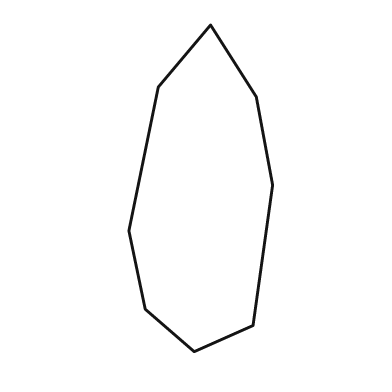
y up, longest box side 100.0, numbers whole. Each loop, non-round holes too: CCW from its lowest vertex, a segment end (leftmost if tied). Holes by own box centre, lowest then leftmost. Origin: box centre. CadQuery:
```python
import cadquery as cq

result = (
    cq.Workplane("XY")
    .moveTo(-2.0, -50.0)
    .lineTo(16.0, -42.0)
    .lineTo(22.0, 1.0)
    .lineTo(17.0, 28.0)
    .lineTo(3.0, 50.0)
    .lineTo(-13.0, 31.0)
    .lineTo(-22.0, -13.0)
    .lineTo(-17.0, -37.0)
    .close()
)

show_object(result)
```